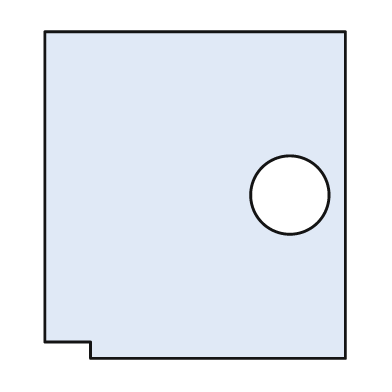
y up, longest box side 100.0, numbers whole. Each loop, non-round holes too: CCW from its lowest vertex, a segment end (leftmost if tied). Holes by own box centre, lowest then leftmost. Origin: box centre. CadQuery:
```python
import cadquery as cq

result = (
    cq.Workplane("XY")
    .moveTo(-32.0, -50.0)
    .lineTo(46.0, -50.0)
    .lineTo(46.0, 50.0)
    .lineTo(-46.0, 50.0)
    .lineTo(-46.0, -45.0)
    .lineTo(-32.0, -45.0)
    .close()
    .moveTo(29.0, 0.0)
    .circle(12.0)
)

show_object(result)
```